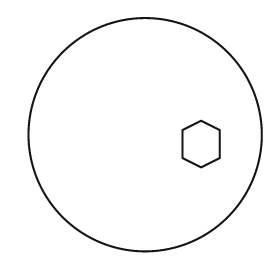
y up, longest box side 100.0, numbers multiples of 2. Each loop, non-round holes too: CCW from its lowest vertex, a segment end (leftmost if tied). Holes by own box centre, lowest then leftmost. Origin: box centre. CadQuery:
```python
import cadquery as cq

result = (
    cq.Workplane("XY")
    .moveTo(0.0, 0.0)
    .circle(50.0)
    .moveTo(24.0, -14.0)
    .lineTo(32.0, -10.0)
    .lineTo(32.0, 2.0)
    .lineTo(24.0, 6.0)
    .lineTo(16.0, 2.0)
    .lineTo(16.0, -10.0)
    .close()
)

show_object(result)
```